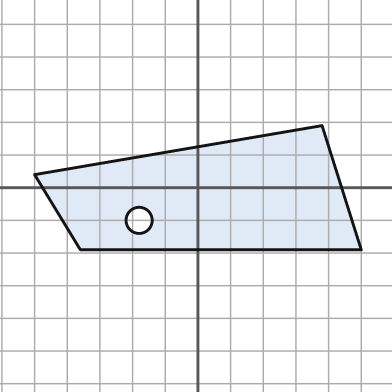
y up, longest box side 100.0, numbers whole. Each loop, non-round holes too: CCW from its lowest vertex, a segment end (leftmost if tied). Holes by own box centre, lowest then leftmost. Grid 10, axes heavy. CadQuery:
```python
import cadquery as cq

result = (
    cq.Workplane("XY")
    .moveTo(-36.0, -19.0)
    .lineTo(50.0, -19.0)
    .lineTo(38.0, 19.0)
    .lineTo(-50.0, 4.0)
    .close()
    .moveTo(-18.0, -10.0)
    .circle(4.0)
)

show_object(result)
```